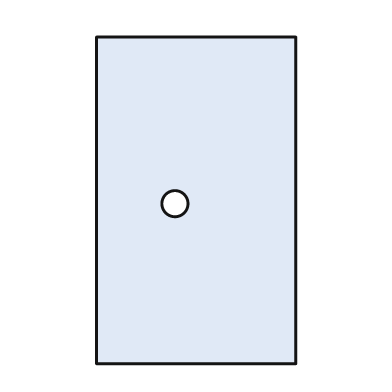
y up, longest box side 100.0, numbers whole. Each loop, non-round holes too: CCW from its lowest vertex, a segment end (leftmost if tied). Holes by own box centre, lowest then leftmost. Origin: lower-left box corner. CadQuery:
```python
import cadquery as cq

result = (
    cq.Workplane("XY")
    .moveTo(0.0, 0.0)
    .lineTo(61.0, 0.0)
    .lineTo(61.0, 100.0)
    .lineTo(0.0, 100.0)
    .close()
    .moveTo(24.0, 49.0)
    .circle(4.0)
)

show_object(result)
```